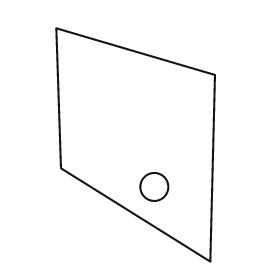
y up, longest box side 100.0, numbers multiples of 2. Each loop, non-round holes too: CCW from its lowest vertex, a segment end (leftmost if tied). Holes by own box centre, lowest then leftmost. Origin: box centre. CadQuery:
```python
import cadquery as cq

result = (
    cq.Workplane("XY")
    .moveTo(32.0, -50.0)
    .lineTo(34.0, 30.0)
    .lineTo(-34.0, 50.0)
    .lineTo(-32.0, -10.0)
    .close()
    .moveTo(8.0, -18.0)
    .circle(6.0)
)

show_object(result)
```